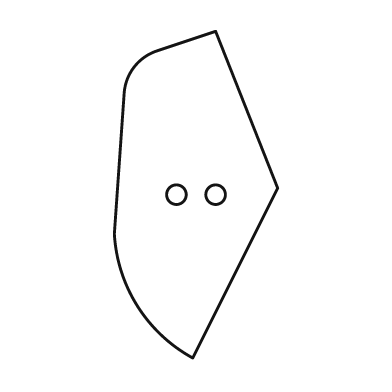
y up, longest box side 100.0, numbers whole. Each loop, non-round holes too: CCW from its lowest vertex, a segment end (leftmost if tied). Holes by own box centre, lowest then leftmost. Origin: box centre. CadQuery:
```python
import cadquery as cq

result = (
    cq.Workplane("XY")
    .moveTo(-1.0, -50.0)
    .lineTo(25.0, 2.0)
    .lineTo(6.0, 50.0)
    .lineTo(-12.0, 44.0)
    .threePointArc((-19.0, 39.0), (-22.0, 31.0))
    .lineTo(-25.0, -12.0)
    .threePointArc((-18.0, -34.0), (-1.0, -50.0))
    .close()
    .moveTo(-6.0, 0.0)
    .circle(3.0)
    .moveTo(6.0, 0.0)
    .circle(3.0)
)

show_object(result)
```